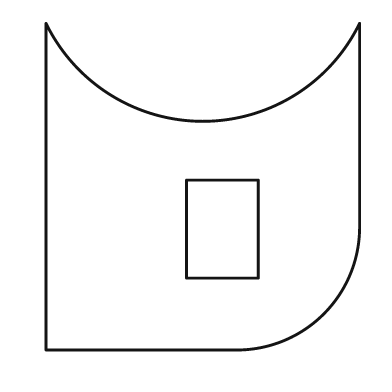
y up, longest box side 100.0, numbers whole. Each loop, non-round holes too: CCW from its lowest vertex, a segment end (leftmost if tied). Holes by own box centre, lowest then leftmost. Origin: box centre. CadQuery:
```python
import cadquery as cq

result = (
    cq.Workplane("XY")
    .moveTo(-48.0, -50.0)
    .lineTo(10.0, -50.0)
    .threePointArc((37.0, -39.0), (48.0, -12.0))
    .lineTo(48.0, 50.0)
    .threePointArc((0.0, 20.0), (-48.0, 50.0))
    .close()
    .moveTo(-5.0, -28.0)
    .lineTo(17.0, -28.0)
    .lineTo(17.0, 2.0)
    .lineTo(-5.0, 2.0)
    .close()
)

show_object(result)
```